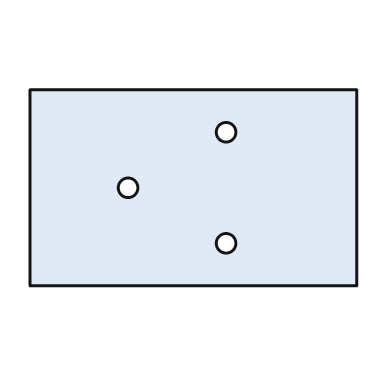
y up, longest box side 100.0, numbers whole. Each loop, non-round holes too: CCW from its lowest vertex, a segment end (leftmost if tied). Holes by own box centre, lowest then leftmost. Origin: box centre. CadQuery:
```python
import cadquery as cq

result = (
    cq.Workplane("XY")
    .moveTo(-50.0, -30.0)
    .lineTo(50.0, -30.0)
    .lineTo(50.0, 30.0)
    .lineTo(-50.0, 30.0)
    .close()
    .moveTo(10.0, -17.0)
    .circle(3.0)
    .moveTo(-20.0, 0.0)
    .circle(3.0)
    .moveTo(10.0, 17.0)
    .circle(3.0)
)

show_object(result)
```